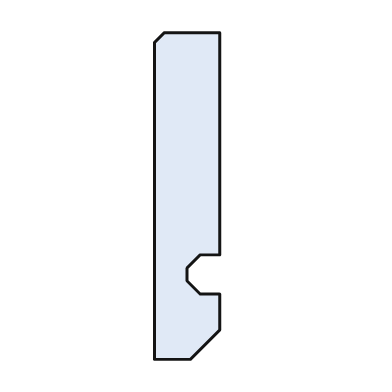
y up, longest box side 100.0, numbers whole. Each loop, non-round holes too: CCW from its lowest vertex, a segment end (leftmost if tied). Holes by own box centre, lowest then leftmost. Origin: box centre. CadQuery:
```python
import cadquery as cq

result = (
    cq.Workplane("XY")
    .moveTo(-10.0, -50.0)
    .lineTo(1.0, -50.0)
    .lineTo(10.0, -41.0)
    .lineTo(10.0, -30.0)
    .lineTo(4.0, -30.0)
    .lineTo(0.0, -26.0)
    .lineTo(0.0, -22.0)
    .lineTo(4.0, -18.0)
    .lineTo(10.0, -18.0)
    .lineTo(10.0, 50.0)
    .lineTo(-7.0, 50.0)
    .lineTo(-10.0, 47.0)
    .close()
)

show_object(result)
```